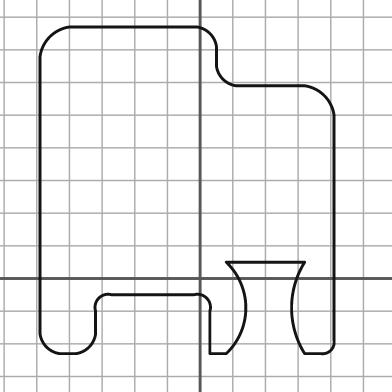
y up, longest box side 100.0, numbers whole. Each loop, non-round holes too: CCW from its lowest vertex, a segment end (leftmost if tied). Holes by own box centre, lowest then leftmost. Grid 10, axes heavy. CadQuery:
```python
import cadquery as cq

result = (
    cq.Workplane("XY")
    .moveTo(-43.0, -23.0)
    .lineTo(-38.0, -23.0)
    .threePointArc((-34.0, -21.0), (-32.0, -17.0))
    .lineTo(-32.0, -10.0)
    .threePointArc((-31.0, -6.0), (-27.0, -5.0))
    .lineTo(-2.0, -5.0)
    .threePointArc((2.0, -6.0), (3.0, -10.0))
    .lineTo(3.0, -23.0)
    .lineTo(8.0, -23.0)
    .threePointArc((14.0, -9.0), (8.0, 5.0))
    .lineTo(32.0, 5.0)
    .threePointArc((28.0, -9.0), (32.0, -23.0))
    .lineTo(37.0, -23.0)
    .threePointArc((40.0, -22.0), (41.0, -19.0))
    .lineTo(41.0, 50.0)
    .threePointArc((38.0, 56.0), (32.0, 59.0))
    .lineTo(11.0, 59.0)
    .threePointArc((7.0, 61.0), (5.0, 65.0))
    .lineTo(5.0, 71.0)
    .threePointArc((3.0, 75.0), (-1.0, 77.0))
    .lineTo(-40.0, 77.0)
    .threePointArc((-46.0, 74.0), (-49.0, 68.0))
    .lineTo(-49.0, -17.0)
    .threePointArc((-47.0, -21.0), (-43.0, -23.0))
    .close()
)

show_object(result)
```